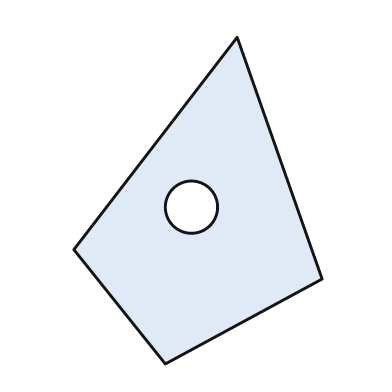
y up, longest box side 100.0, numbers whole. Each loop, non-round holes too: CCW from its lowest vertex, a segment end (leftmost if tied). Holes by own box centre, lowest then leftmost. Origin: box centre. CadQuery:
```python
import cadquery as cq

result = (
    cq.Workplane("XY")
    .moveTo(-10.0, -50.0)
    .lineTo(38.0, -24.0)
    .lineTo(12.0, 50.0)
    .lineTo(-38.0, -15.0)
    .close()
    .moveTo(-2.0, -2.0)
    .circle(8.0)
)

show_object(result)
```